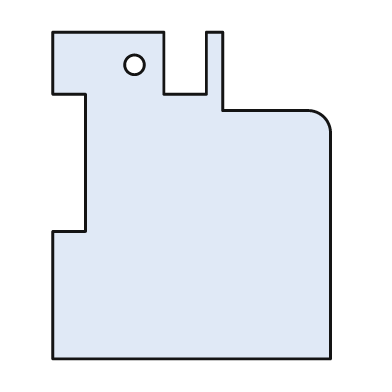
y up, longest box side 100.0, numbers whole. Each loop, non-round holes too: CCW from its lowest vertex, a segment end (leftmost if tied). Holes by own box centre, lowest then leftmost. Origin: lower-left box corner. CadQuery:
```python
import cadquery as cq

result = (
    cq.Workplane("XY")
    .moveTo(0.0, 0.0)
    .lineTo(85.0, 0.0)
    .lineTo(85.0, 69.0)
    .threePointArc((83.0, 74.0), (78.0, 76.0))
    .lineTo(52.0, 76.0)
    .lineTo(52.0, 100.0)
    .lineTo(47.0, 100.0)
    .lineTo(47.0, 81.0)
    .lineTo(34.0, 81.0)
    .lineTo(34.0, 100.0)
    .lineTo(0.0, 100.0)
    .lineTo(0.0, 81.0)
    .lineTo(10.0, 81.0)
    .lineTo(10.0, 39.0)
    .lineTo(0.0, 39.0)
    .close()
    .moveTo(25.0, 90.0)
    .circle(3.0)
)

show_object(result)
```